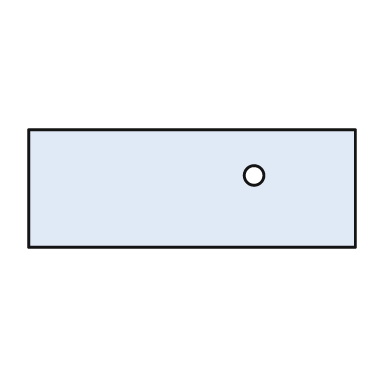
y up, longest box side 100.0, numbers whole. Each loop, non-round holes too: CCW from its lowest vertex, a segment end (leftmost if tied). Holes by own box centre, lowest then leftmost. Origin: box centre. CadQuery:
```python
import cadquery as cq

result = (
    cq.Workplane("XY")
    .moveTo(-50.0, -18.0)
    .lineTo(50.0, -18.0)
    .lineTo(50.0, 18.0)
    .lineTo(-50.0, 18.0)
    .close()
    .moveTo(19.0, 4.0)
    .circle(3.0)
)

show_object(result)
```